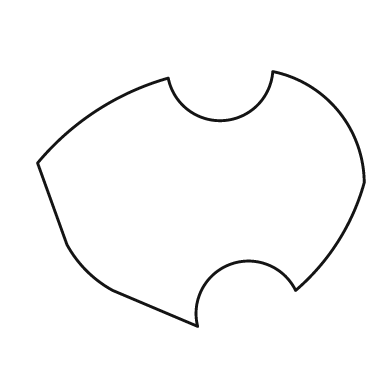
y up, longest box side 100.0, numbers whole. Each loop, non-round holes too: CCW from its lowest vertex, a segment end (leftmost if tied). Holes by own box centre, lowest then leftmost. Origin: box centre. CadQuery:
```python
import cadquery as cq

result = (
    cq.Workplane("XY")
    .moveTo(-1.0, -39.0)
    .threePointArc((9.0, -20.0), (29.0, -28.0))
    .threePointArc((42.0, -13.0), (50.0, 5.0))
    .threePointArc((42.0, 27.0), (22.0, 39.0))
    .threePointArc((7.0, 24.0), (-10.0, 37.0))
    .threePointArc((-32.0, 27.0), (-50.0, 11.0))
    .lineTo(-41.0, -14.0)
    .threePointArc((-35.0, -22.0), (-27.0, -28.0))
    .close()
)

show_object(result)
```